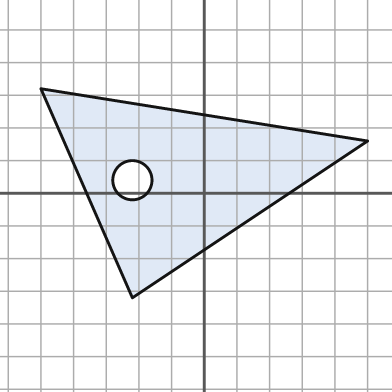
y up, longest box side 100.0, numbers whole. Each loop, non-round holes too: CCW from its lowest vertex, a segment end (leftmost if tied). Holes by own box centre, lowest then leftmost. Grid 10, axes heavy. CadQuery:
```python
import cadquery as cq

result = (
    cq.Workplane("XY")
    .moveTo(-22.0, -32.0)
    .lineTo(50.0, 16.0)
    .lineTo(-50.0, 32.0)
    .close()
    .moveTo(-22.0, 4.0)
    .circle(6.0)
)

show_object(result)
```